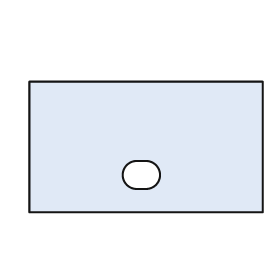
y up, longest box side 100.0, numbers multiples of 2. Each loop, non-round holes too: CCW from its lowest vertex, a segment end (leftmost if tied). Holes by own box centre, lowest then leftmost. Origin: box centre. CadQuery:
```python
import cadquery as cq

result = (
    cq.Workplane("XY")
    .moveTo(-50.0, -28.0)
    .lineTo(50.0, -28.0)
    .lineTo(50.0, 28.0)
    .lineTo(-50.0, 28.0)
    .close()
    .moveTo(-4.0, -18.0)
    .lineTo(0.0, -18.0)
    .threePointArc((6.0, -12.0), (0.0, -6.0))
    .lineTo(-4.0, -6.0)
    .threePointArc((-10.0, -12.0), (-4.0, -18.0))
    .close()
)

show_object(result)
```